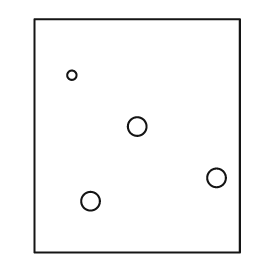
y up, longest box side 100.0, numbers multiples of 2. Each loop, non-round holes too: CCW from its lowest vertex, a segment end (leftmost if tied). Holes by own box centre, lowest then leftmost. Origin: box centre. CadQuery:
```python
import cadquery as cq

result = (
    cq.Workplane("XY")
    .moveTo(-44.0, -50.0)
    .lineTo(44.0, -50.0)
    .lineTo(44.0, 50.0)
    .lineTo(-44.0, 50.0)
    .close()
    .moveTo(-20.0, -28.0)
    .circle(4.0)
    .moveTo(34.0, -18.0)
    .circle(4.0)
    .moveTo(0.0, 4.0)
    .circle(4.0)
    .moveTo(-28.0, 26.0)
    .circle(2.0)
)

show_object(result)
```